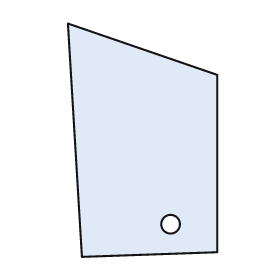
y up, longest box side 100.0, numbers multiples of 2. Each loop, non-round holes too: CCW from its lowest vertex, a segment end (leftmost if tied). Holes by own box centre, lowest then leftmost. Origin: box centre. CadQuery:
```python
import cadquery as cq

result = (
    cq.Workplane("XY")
    .moveTo(-26.0, -50.0)
    .lineTo(32.0, -48.0)
    .lineTo(32.0, 28.0)
    .lineTo(-32.0, 50.0)
    .close()
    .moveTo(12.0, -36.0)
    .circle(4.0)
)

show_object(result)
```